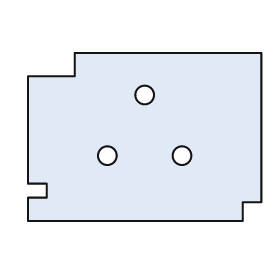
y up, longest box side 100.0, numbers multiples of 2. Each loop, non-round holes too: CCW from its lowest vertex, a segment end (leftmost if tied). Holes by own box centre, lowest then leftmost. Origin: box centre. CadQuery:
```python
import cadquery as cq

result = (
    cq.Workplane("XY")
    .moveTo(-50.0, -36.0)
    .lineTo(42.0, -36.0)
    .lineTo(42.0, -28.0)
    .lineTo(50.0, -28.0)
    .lineTo(50.0, 36.0)
    .lineTo(-30.0, 36.0)
    .lineTo(-30.0, 26.0)
    .lineTo(-50.0, 26.0)
    .lineTo(-50.0, -20.0)
    .lineTo(-42.0, -20.0)
    .lineTo(-42.0, -26.0)
    .lineTo(-50.0, -26.0)
    .close()
    .moveTo(-16.0, -8.0)
    .circle(4.0)
    .moveTo(16.0, -8.0)
    .circle(4.0)
    .moveTo(0.0, 18.0)
    .circle(4.0)
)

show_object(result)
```